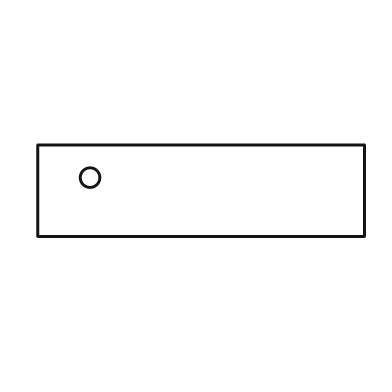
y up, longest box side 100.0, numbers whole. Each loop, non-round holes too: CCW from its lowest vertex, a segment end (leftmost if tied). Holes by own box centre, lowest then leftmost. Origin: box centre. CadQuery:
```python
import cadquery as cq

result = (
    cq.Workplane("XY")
    .moveTo(-50.0, -14.0)
    .lineTo(50.0, -14.0)
    .lineTo(50.0, 14.0)
    .lineTo(-50.0, 14.0)
    .close()
    .moveTo(-34.0, 4.0)
    .circle(3.0)
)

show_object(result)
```